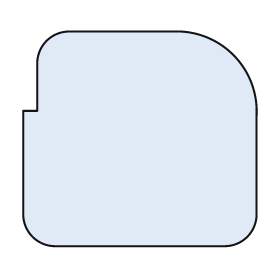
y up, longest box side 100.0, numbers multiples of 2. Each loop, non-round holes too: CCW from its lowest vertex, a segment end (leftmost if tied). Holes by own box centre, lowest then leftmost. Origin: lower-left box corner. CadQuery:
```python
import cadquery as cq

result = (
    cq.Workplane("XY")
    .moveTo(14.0, 0.0)
    .lineTo(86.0, 0.0)
    .threePointArc((96.0, 4.0), (100.0, 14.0))
    .lineTo(100.0, 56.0)
    .threePointArc((90.0, 82.0), (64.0, 92.0))
    .lineTo(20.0, 92.0)
    .threePointArc((10.0, 88.0), (6.0, 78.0))
    .lineTo(6.0, 58.0)
    .lineTo(0.0, 58.0)
    .lineTo(0.0, 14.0)
    .threePointArc((4.0, 4.0), (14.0, 0.0))
    .close()
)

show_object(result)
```